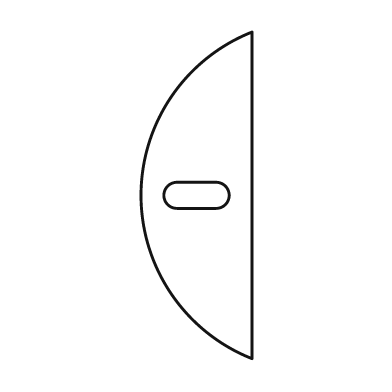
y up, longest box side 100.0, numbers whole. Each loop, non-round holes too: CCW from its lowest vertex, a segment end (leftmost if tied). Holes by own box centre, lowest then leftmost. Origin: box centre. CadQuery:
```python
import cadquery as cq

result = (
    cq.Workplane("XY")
    .moveTo(17.0, -50.0)
    .lineTo(17.0, 50.0)
    .threePointArc((-17.0, 0.0), (17.0, -50.0))
    .close()
    .moveTo(-6.0, -4.0)
    .lineTo(6.0, -4.0)
    .threePointArc((10.0, 0.0), (6.0, 4.0))
    .lineTo(-6.0, 4.0)
    .threePointArc((-10.0, 0.0), (-6.0, -4.0))
    .close()
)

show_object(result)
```